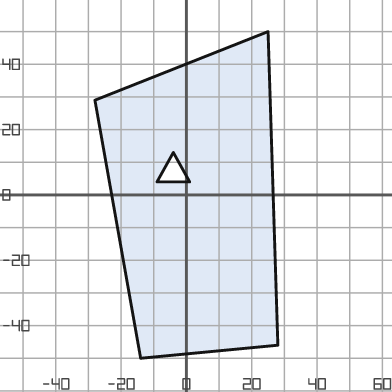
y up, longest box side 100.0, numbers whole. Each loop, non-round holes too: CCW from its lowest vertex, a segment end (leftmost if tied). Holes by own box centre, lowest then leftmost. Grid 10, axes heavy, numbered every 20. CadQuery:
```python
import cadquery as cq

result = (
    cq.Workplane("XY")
    .moveTo(-14.0, -50.0)
    .lineTo(28.0, -46.0)
    .lineTo(25.0, 50.0)
    .lineTo(-28.0, 29.0)
    .close()
    .moveTo(-9.0, 4.0)
    .lineTo(1.0, 4.0)
    .lineTo(-4.0, 13.0)
    .close()
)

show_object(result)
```